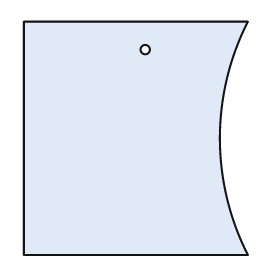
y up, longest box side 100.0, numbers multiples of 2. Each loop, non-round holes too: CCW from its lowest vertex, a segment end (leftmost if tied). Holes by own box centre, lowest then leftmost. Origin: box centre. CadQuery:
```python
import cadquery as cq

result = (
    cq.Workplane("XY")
    .moveTo(-48.0, -50.0)
    .lineTo(48.0, -50.0)
    .threePointArc((36.0, 0.0), (48.0, 50.0))
    .lineTo(-48.0, 50.0)
    .close()
    .moveTo(4.0, 38.0)
    .circle(2.0)
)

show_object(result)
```